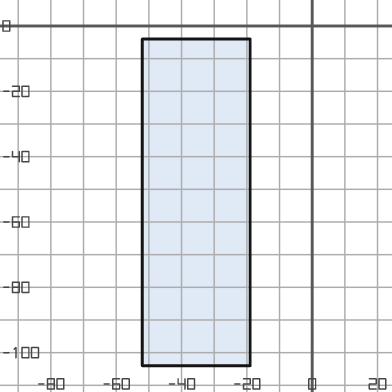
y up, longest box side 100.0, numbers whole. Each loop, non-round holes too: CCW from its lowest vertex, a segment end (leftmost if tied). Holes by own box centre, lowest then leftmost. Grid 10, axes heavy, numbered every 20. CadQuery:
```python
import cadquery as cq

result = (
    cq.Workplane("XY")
    .moveTo(-52.0, -104.0)
    .lineTo(-19.0, -104.0)
    .lineTo(-19.0, -4.0)
    .lineTo(-52.0, -4.0)
    .close()
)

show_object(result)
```